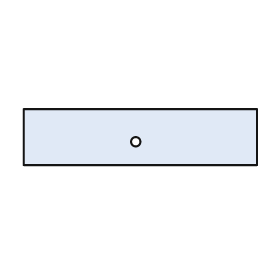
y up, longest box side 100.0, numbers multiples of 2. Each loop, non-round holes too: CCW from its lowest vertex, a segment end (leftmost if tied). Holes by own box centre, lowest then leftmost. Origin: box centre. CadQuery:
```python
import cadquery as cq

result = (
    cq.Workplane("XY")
    .moveTo(-50.0, -12.0)
    .lineTo(50.0, -12.0)
    .lineTo(50.0, 12.0)
    .lineTo(-50.0, 12.0)
    .close()
    .moveTo(-2.0, -2.0)
    .circle(2.0)
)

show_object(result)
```